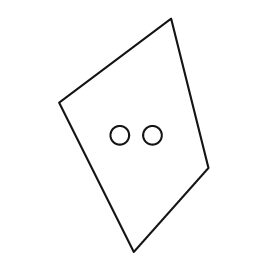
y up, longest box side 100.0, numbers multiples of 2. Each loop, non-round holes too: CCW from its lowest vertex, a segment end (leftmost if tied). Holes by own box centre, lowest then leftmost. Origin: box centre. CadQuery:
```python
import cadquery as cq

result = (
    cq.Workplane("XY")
    .moveTo(0.0, -50.0)
    .lineTo(32.0, -14.0)
    .lineTo(16.0, 50.0)
    .lineTo(-32.0, 14.0)
    .close()
    .moveTo(-6.0, 0.0)
    .circle(4.0)
    .moveTo(8.0, 0.0)
    .circle(4.0)
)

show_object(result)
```